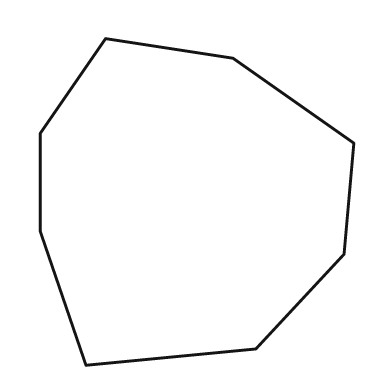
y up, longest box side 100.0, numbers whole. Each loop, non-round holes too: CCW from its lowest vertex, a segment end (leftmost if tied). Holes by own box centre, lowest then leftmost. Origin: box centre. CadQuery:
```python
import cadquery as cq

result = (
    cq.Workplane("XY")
    .moveTo(-34.0, -50.0)
    .lineTo(18.0, -45.0)
    .lineTo(45.0, -16.0)
    .lineTo(48.0, 18.0)
    .lineTo(11.0, 44.0)
    .lineTo(-28.0, 50.0)
    .lineTo(-48.0, 21.0)
    .lineTo(-48.0, -9.0)
    .close()
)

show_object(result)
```